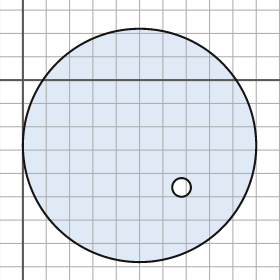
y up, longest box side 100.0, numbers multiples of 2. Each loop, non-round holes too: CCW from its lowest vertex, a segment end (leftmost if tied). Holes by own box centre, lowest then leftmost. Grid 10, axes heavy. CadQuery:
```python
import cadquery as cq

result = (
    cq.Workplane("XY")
    .moveTo(50.0, -28.0)
    .circle(50.0)
    .moveTo(68.0, -46.0)
    .circle(4.0)
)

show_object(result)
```